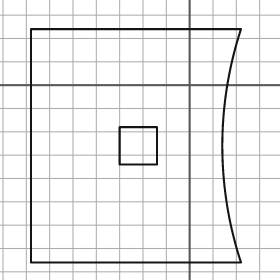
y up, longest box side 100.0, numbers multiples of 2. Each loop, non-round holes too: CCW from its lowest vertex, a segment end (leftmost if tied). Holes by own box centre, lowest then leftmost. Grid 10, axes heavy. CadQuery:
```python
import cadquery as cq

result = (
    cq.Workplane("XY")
    .moveTo(-68.0, -76.0)
    .lineTo(22.0, -76.0)
    .threePointArc((14.0, -26.0), (22.0, 24.0))
    .lineTo(-68.0, 24.0)
    .close()
    .moveTo(-30.0, -34.0)
    .lineTo(-14.0, -34.0)
    .lineTo(-14.0, -18.0)
    .lineTo(-30.0, -18.0)
    .close()
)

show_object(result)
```